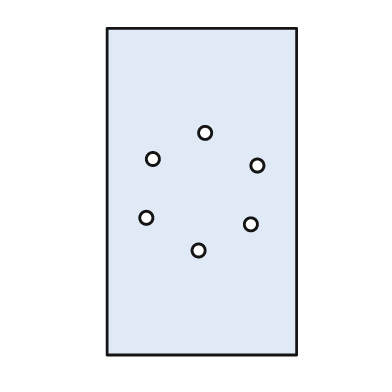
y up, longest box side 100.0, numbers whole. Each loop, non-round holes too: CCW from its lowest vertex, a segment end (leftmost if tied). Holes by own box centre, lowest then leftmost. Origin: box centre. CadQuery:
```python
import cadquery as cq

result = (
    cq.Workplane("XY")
    .moveTo(-29.0, -50.0)
    .lineTo(29.0, -50.0)
    .lineTo(29.0, 50.0)
    .lineTo(-29.0, 50.0)
    .close()
    .moveTo(-1.0, -18.0)
    .circle(2.0)
    .moveTo(15.0, -10.0)
    .circle(2.0)
    .moveTo(-17.0, -8.0)
    .circle(2.0)
    .moveTo(17.0, 8.0)
    .circle(2.0)
    .moveTo(-15.0, 10.0)
    .circle(2.0)
    .moveTo(1.0, 18.0)
    .circle(2.0)
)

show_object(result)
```